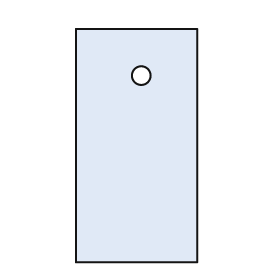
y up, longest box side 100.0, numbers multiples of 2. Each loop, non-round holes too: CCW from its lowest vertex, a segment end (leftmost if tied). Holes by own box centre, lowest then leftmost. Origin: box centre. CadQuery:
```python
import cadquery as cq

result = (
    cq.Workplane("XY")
    .moveTo(-26.0, -50.0)
    .lineTo(26.0, -50.0)
    .lineTo(26.0, 50.0)
    .lineTo(-26.0, 50.0)
    .close()
    .moveTo(2.0, 30.0)
    .circle(4.0)
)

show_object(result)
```